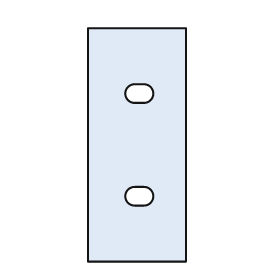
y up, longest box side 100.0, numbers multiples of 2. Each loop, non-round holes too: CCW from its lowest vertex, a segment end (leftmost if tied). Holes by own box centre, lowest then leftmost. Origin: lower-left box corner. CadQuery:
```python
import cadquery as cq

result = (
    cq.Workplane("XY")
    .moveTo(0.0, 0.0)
    .lineTo(42.0, 0.0)
    .lineTo(42.0, 100.0)
    .lineTo(0.0, 100.0)
    .close()
    .moveTo(20.0, 24.0)
    .lineTo(24.0, 24.0)
    .threePointArc((28.0, 28.0), (24.0, 32.0))
    .lineTo(20.0, 32.0)
    .threePointArc((16.0, 28.0), (20.0, 24.0))
    .close()
    .moveTo(20.0, 68.0)
    .lineTo(24.0, 68.0)
    .threePointArc((28.0, 72.0), (24.0, 76.0))
    .lineTo(20.0, 76.0)
    .threePointArc((16.0, 72.0), (20.0, 68.0))
    .close()
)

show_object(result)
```